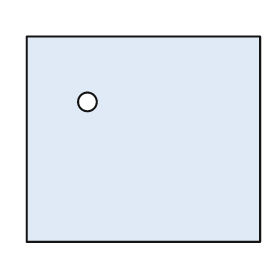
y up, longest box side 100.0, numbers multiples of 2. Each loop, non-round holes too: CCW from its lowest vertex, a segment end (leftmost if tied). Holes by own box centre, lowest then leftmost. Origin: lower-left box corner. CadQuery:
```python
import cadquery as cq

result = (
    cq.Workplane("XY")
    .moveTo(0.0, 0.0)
    .lineTo(100.0, 0.0)
    .lineTo(100.0, 88.0)
    .lineTo(0.0, 88.0)
    .close()
    .moveTo(26.0, 60.0)
    .circle(4.0)
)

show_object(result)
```